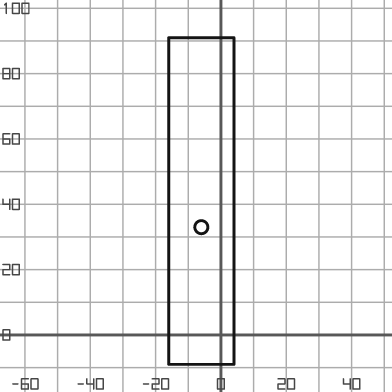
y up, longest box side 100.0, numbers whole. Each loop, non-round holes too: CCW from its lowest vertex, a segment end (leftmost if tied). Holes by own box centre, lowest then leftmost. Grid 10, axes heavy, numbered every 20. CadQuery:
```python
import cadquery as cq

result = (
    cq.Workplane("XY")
    .moveTo(-16.0, -9.0)
    .lineTo(4.0, -9.0)
    .lineTo(4.0, 91.0)
    .lineTo(-16.0, 91.0)
    .close()
    .moveTo(-6.0, 33.0)
    .circle(2.0)
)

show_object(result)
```